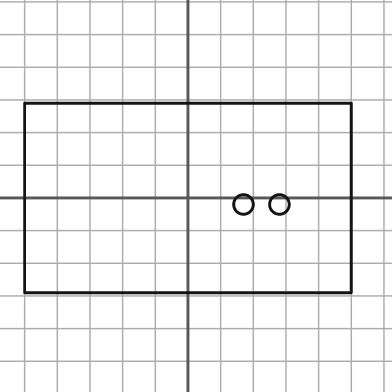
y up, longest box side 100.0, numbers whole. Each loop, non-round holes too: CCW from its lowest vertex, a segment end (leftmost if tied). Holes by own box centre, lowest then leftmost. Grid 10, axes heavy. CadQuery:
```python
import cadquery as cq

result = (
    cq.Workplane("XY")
    .moveTo(-50.0, -29.0)
    .lineTo(50.0, -29.0)
    .lineTo(50.0, 29.0)
    .lineTo(-50.0, 29.0)
    .close()
    .moveTo(17.0, -2.0)
    .circle(3.0)
    .moveTo(28.0, -2.0)
    .circle(3.0)
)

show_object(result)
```